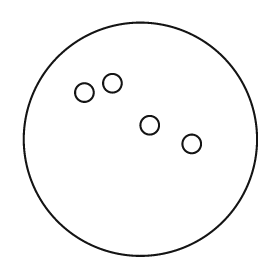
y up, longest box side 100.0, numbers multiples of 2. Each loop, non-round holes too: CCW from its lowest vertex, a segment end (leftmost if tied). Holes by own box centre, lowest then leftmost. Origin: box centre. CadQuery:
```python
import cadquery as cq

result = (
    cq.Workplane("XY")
    .moveTo(0.0, 0.0)
    .circle(50.0)
    .moveTo(22.0, -2.0)
    .circle(4.0)
    .moveTo(4.0, 6.0)
    .circle(4.0)
    .moveTo(-24.0, 20.0)
    .circle(4.0)
    .moveTo(-12.0, 24.0)
    .circle(4.0)
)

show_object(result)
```